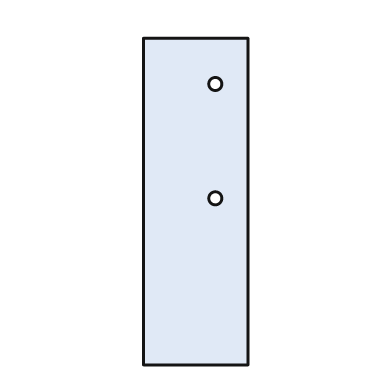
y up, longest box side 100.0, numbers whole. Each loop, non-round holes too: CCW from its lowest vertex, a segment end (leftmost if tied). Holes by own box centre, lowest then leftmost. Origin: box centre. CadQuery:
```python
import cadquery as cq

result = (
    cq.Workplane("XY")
    .moveTo(-16.0, -50.0)
    .lineTo(16.0, -50.0)
    .lineTo(16.0, 50.0)
    .lineTo(-16.0, 50.0)
    .close()
    .moveTo(6.0, 1.0)
    .circle(2.0)
    .moveTo(6.0, 36.0)
    .circle(2.0)
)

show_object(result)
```